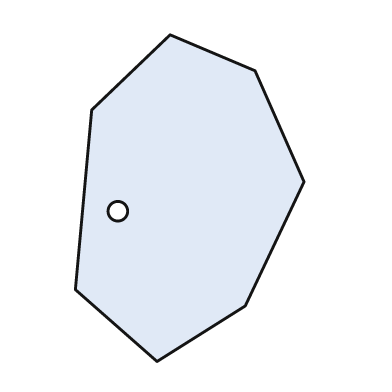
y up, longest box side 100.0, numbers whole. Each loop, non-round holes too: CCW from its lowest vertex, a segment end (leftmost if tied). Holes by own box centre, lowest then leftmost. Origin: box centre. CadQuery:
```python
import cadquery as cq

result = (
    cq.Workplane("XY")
    .moveTo(-10.0, -50.0)
    .lineTo(17.0, -33.0)
    .lineTo(35.0, 5.0)
    .lineTo(20.0, 39.0)
    .lineTo(-6.0, 50.0)
    .lineTo(-30.0, 27.0)
    .lineTo(-35.0, -28.0)
    .close()
    .moveTo(-22.0, -4.0)
    .circle(3.0)
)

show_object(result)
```